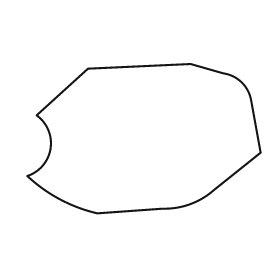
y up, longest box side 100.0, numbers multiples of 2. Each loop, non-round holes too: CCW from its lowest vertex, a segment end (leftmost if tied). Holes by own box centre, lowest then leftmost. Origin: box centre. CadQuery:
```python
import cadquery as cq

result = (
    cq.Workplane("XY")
    .moveTo(-20.0, -32.0)
    .lineTo(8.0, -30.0)
    .threePointArc((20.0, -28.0), (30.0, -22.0))
    .lineTo(50.0, -6.0)
    .lineTo(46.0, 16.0)
    .threePointArc((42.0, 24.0), (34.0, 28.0))
    .lineTo(20.0, 32.0)
    .lineTo(-24.0, 30.0)
    .lineTo(-46.0, 10.0)
    .threePointArc((-40.0, -4.0), (-50.0, -16.0))
    .threePointArc((-36.0, -26.0), (-20.0, -32.0))
    .close()
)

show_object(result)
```